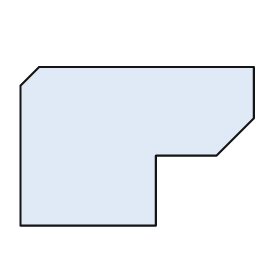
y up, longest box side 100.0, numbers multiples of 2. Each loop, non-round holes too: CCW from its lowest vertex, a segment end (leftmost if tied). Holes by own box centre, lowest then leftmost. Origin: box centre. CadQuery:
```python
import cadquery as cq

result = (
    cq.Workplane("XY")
    .moveTo(-50.0, -34.0)
    .lineTo(8.0, -34.0)
    .lineTo(8.0, -4.0)
    .lineTo(34.0, -4.0)
    .lineTo(50.0, 12.0)
    .lineTo(50.0, 34.0)
    .lineTo(-42.0, 34.0)
    .lineTo(-50.0, 26.0)
    .close()
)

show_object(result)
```